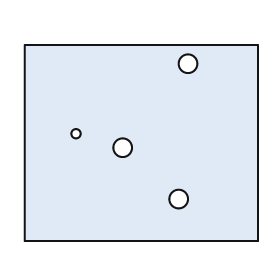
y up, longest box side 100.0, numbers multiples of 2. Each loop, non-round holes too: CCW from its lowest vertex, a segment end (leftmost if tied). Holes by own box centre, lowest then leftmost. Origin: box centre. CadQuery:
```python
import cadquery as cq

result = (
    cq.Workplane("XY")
    .moveTo(-50.0, -42.0)
    .lineTo(50.0, -42.0)
    .lineTo(50.0, 42.0)
    .lineTo(-50.0, 42.0)
    .close()
    .moveTo(16.0, -24.0)
    .circle(4.0)
    .moveTo(-8.0, -2.0)
    .circle(4.0)
    .moveTo(-28.0, 4.0)
    .circle(2.0)
    .moveTo(20.0, 34.0)
    .circle(4.0)
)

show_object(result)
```